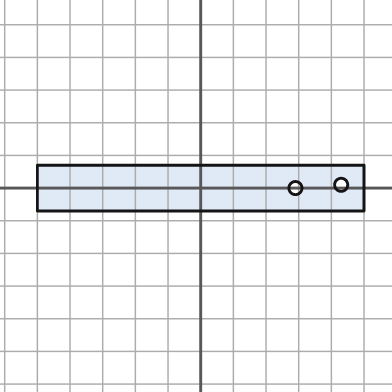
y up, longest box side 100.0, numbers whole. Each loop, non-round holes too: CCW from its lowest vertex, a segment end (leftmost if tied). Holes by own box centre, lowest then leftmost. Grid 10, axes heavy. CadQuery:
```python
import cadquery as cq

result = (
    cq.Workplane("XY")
    .moveTo(-50.0, -7.0)
    .lineTo(50.0, -7.0)
    .lineTo(50.0, 7.0)
    .lineTo(-50.0, 7.0)
    .close()
    .moveTo(29.0, 0.0)
    .circle(2.0)
    .moveTo(43.0, 1.0)
    .circle(2.0)
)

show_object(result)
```